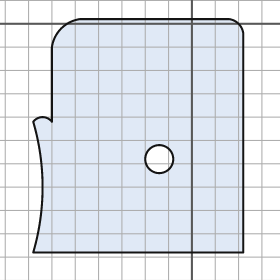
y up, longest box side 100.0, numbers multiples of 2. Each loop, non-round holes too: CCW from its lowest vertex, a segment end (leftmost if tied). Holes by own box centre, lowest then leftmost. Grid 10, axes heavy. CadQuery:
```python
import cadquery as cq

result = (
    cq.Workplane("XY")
    .moveTo(-68.0, -98.0)
    .lineTo(22.0, -98.0)
    .lineTo(22.0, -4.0)
    .threePointArc((20.0, 0.0), (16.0, 2.0))
    .lineTo(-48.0, 2.0)
    .threePointArc((-56.0, -2.0), (-60.0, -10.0))
    .lineTo(-60.0, -42.0)
    .threePointArc((-64.0, -40.0), (-68.0, -42.0))
    .threePointArc((-64.0, -70.0), (-68.0, -98.0))
    .close()
    .moveTo(-14.0, -58.0)
    .circle(6.0)
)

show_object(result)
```